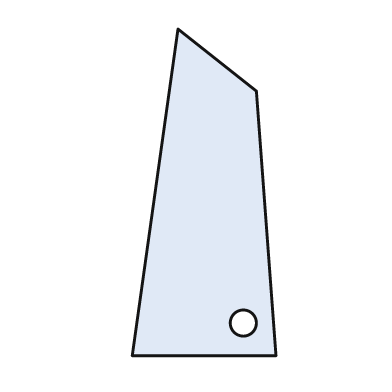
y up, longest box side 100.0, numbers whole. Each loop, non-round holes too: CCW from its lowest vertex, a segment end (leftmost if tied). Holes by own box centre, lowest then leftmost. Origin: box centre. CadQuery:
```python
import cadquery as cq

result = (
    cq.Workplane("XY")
    .moveTo(-22.0, -50.0)
    .lineTo(22.0, -50.0)
    .lineTo(16.0, 31.0)
    .lineTo(-8.0, 50.0)
    .close()
    .moveTo(12.0, -40.0)
    .circle(4.0)
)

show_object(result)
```